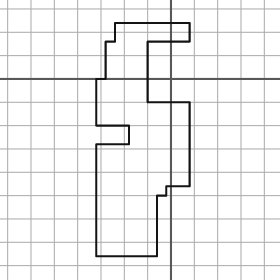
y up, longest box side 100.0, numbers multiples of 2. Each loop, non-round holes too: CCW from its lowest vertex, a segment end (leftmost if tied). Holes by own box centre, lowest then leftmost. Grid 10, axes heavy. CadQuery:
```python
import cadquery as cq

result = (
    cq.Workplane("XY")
    .moveTo(-32.0, -76.0)
    .lineTo(-6.0, -76.0)
    .lineTo(-6.0, -50.0)
    .lineTo(-2.0, -50.0)
    .lineTo(-2.0, -46.0)
    .lineTo(8.0, -46.0)
    .lineTo(8.0, -10.0)
    .lineTo(-10.0, -10.0)
    .lineTo(-10.0, 16.0)
    .lineTo(8.0, 16.0)
    .lineTo(8.0, 24.0)
    .lineTo(-24.0, 24.0)
    .lineTo(-24.0, 16.0)
    .lineTo(-28.0, 16.0)
    .lineTo(-28.0, 0.0)
    .lineTo(-32.0, 0.0)
    .lineTo(-32.0, -20.0)
    .lineTo(-18.0, -20.0)
    .lineTo(-18.0, -28.0)
    .lineTo(-32.0, -28.0)
    .close()
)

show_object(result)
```